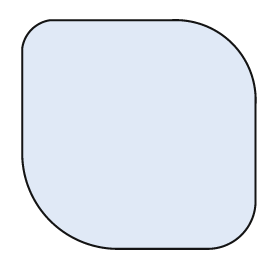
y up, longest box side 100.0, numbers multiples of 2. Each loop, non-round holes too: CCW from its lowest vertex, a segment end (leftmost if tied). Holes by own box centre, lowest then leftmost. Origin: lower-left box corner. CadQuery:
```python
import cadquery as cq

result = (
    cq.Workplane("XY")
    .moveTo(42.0, 0.0)
    .lineTo(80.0, 0.0)
    .threePointArc((94.0, 6.0), (100.0, 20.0))
    .lineTo(100.0, 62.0)
    .threePointArc((90.0, 88.0), (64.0, 98.0))
    .lineTo(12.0, 98.0)
    .threePointArc((4.0, 94.0), (0.0, 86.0))
    .lineTo(0.0, 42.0)
    .threePointArc((12.0, 12.0), (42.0, 0.0))
    .close()
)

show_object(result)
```